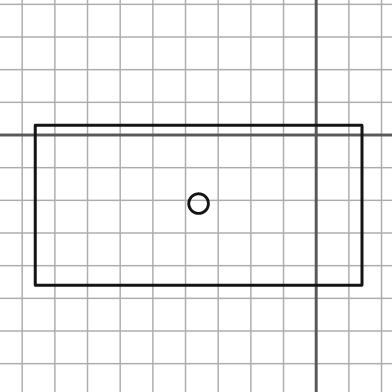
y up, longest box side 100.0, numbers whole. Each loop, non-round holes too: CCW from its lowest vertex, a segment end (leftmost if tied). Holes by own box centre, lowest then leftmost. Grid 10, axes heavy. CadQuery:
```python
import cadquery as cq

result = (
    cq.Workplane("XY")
    .moveTo(-86.0, -46.0)
    .lineTo(14.0, -46.0)
    .lineTo(14.0, 3.0)
    .lineTo(-86.0, 3.0)
    .close()
    .moveTo(-36.0, -21.0)
    .circle(3.0)
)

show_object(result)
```